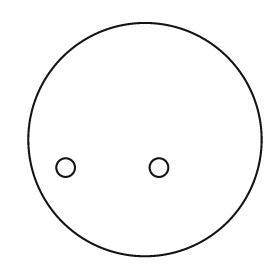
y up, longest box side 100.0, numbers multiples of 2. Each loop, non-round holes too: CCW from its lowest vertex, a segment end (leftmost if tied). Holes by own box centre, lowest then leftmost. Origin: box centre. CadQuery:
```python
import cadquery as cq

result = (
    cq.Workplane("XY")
    .moveTo(0.0, 0.0)
    .circle(50.0)
    .moveTo(-34.0, -12.0)
    .circle(4.0)
    .moveTo(6.0, -12.0)
    .circle(4.0)
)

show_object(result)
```